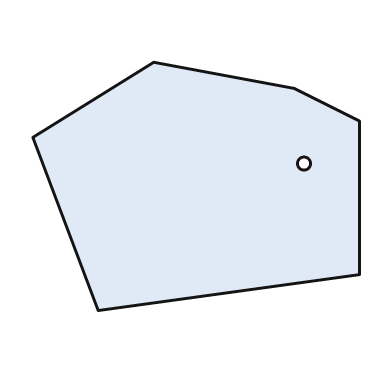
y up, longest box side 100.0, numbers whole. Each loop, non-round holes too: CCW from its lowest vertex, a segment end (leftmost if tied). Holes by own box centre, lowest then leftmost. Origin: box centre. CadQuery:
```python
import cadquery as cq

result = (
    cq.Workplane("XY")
    .moveTo(-30.0, -38.0)
    .lineTo(50.0, -27.0)
    .lineTo(50.0, 20.0)
    .lineTo(30.0, 30.0)
    .lineTo(-13.0, 38.0)
    .lineTo(-50.0, 15.0)
    .close()
    .moveTo(33.0, 7.0)
    .circle(2.0)
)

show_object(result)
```